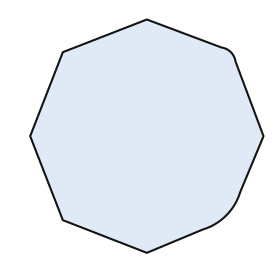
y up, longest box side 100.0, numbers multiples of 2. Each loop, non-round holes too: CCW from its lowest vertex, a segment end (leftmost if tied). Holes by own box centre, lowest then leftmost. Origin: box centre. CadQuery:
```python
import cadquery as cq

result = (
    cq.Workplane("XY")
    .moveTo(0.0, -50.0)
    .lineTo(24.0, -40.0)
    .threePointArc((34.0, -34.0), (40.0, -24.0))
    .lineTo(50.0, 0.0)
    .lineTo(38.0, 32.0)
    .threePointArc((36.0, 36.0), (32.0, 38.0))
    .lineTo(0.0, 50.0)
    .lineTo(-36.0, 36.0)
    .lineTo(-50.0, 0.0)
    .lineTo(-36.0, -36.0)
    .close()
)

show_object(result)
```